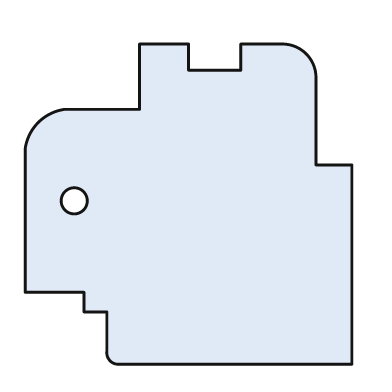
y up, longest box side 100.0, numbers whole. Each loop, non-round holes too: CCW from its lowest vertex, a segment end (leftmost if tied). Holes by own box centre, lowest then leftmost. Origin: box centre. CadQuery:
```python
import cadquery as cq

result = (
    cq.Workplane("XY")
    .moveTo(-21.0, -49.0)
    .lineTo(50.0, -49.0)
    .lineTo(50.0, 12.0)
    .lineTo(39.0, 12.0)
    .lineTo(39.0, 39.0)
    .threePointArc((36.0, 46.0), (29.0, 49.0))
    .lineTo(16.0, 49.0)
    .lineTo(16.0, 41.0)
    .lineTo(0.0, 41.0)
    .lineTo(0.0, 49.0)
    .lineTo(-15.0, 49.0)
    .lineTo(-15.0, 29.0)
    .lineTo(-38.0, 29.0)
    .threePointArc((-46.0, 25.0), (-50.0, 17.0))
    .lineTo(-50.0, -27.0)
    .lineTo(-32.0, -27.0)
    .lineTo(-32.0, -33.0)
    .lineTo(-25.0, -33.0)
    .lineTo(-25.0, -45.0)
    .threePointArc((-24.0, -48.0), (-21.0, -49.0))
    .close()
    .moveTo(-35.0, 1.0)
    .circle(4.0)
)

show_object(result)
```